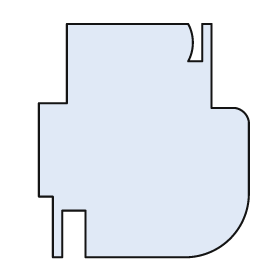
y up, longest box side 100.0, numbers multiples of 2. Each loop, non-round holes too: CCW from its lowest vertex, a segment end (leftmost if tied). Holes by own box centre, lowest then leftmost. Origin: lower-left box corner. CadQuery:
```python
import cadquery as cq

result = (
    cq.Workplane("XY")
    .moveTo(6.0, 0.0)
    .lineTo(10.0, 0.0)
    .lineTo(10.0, 20.0)
    .lineTo(20.0, 20.0)
    .lineTo(20.0, 0.0)
    .lineTo(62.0, 0.0)
    .threePointArc((82.0, 8.0), (90.0, 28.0))
    .lineTo(90.0, 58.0)
    .threePointArc((88.0, 62.0), (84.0, 64.0))
    .lineTo(74.0, 64.0)
    .lineTo(74.0, 100.0)
    .lineTo(70.0, 100.0)
    .lineTo(70.0, 84.0)
    .lineTo(64.0, 84.0)
    .threePointArc((66.0, 92.0), (64.0, 100.0))
    .lineTo(12.0, 100.0)
    .lineTo(12.0, 66.0)
    .lineTo(0.0, 66.0)
    .lineTo(0.0, 26.0)
    .lineTo(6.0, 26.0)
    .close()
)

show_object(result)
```